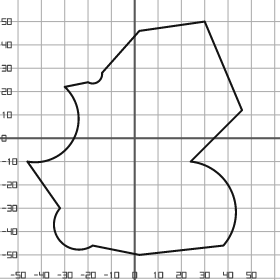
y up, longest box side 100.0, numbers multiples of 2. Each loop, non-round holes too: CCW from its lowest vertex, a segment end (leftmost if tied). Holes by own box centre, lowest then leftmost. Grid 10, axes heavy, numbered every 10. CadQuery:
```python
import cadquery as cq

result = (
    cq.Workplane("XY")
    .moveTo(2.0, -50.0)
    .lineTo(38.0, -46.0)
    .threePointArc((42.0, -24.0), (24.0, -10.0))
    .lineTo(46.0, 12.0)
    .lineTo(30.0, 50.0)
    .lineTo(2.0, 46.0)
    .lineTo(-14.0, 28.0)
    .threePointArc((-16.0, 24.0), (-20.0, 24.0))
    .lineTo(-30.0, 22.0)
    .threePointArc((-26.0, 0.0), (-46.0, -10.0))
    .lineTo(-32.0, -30.0)
    .threePointArc((-32.0, -44.0), (-18.0, -46.0))
    .close()
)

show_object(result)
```